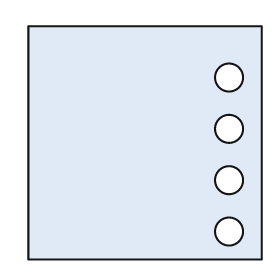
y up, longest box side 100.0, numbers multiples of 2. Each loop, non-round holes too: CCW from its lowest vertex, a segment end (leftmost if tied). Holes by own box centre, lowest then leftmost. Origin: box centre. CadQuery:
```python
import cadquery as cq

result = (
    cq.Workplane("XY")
    .moveTo(-50.0, -50.0)
    .lineTo(50.0, -50.0)
    .lineTo(50.0, 50.0)
    .lineTo(-50.0, 50.0)
    .close()
    .moveTo(36.0, -38.0)
    .circle(6.0)
    .moveTo(36.0, -16.0)
    .circle(6.0)
    .moveTo(36.0, 6.0)
    .circle(6.0)
    .moveTo(36.0, 28.0)
    .circle(6.0)
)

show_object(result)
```